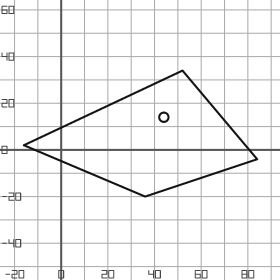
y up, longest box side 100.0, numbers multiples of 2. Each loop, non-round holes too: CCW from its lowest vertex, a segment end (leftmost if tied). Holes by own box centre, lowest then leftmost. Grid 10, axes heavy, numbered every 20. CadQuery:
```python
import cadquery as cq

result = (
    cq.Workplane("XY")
    .moveTo(36.0, -20.0)
    .lineTo(84.0, -4.0)
    .lineTo(52.0, 34.0)
    .lineTo(-16.0, 2.0)
    .close()
    .moveTo(44.0, 14.0)
    .circle(2.0)
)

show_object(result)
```